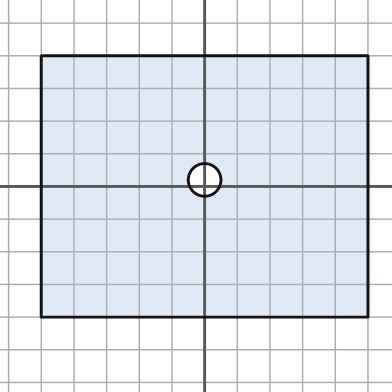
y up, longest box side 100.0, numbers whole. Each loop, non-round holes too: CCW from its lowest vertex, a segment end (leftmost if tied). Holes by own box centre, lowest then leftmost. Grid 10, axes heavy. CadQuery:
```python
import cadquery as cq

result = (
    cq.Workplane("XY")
    .moveTo(-50.0, -40.0)
    .lineTo(50.0, -40.0)
    .lineTo(50.0, 40.0)
    .lineTo(-50.0, 40.0)
    .close()
    .moveTo(0.0, 2.0)
    .circle(5.0)
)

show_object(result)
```